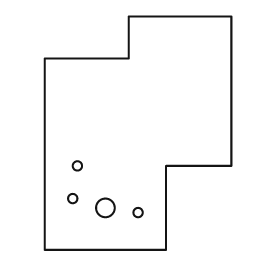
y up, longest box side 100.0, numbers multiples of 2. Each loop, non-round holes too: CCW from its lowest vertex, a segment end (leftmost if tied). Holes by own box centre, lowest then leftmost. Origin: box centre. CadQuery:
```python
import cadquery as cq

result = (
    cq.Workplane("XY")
    .moveTo(-40.0, -50.0)
    .lineTo(12.0, -50.0)
    .lineTo(12.0, -14.0)
    .lineTo(40.0, -14.0)
    .lineTo(40.0, 50.0)
    .lineTo(-4.0, 50.0)
    .lineTo(-4.0, 32.0)
    .lineTo(-40.0, 32.0)
    .close()
    .moveTo(0.0, -34.0)
    .circle(2.0)
    .moveTo(-14.0, -32.0)
    .circle(4.0)
    .moveTo(-28.0, -28.0)
    .circle(2.0)
    .moveTo(-26.0, -14.0)
    .circle(2.0)
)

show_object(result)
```